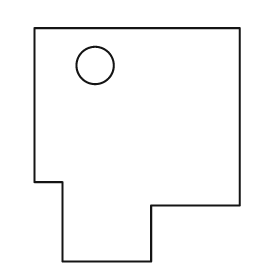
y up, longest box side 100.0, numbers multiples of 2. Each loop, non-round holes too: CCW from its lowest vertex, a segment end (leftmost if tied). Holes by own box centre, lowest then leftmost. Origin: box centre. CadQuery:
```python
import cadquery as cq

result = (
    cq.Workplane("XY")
    .moveTo(-32.0, -50.0)
    .lineTo(6.0, -50.0)
    .lineTo(6.0, -26.0)
    .lineTo(44.0, -26.0)
    .lineTo(44.0, 50.0)
    .lineTo(-44.0, 50.0)
    .lineTo(-44.0, -16.0)
    .lineTo(-32.0, -16.0)
    .close()
    .moveTo(-18.0, 34.0)
    .circle(8.0)
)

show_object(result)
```